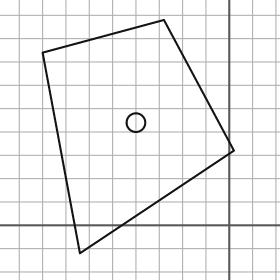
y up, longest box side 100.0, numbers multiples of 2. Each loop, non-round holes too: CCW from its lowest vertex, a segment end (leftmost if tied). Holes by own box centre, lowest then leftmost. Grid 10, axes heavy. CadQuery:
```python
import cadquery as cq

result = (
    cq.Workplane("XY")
    .moveTo(-64.0, -12.0)
    .lineTo(2.0, 32.0)
    .lineTo(-28.0, 88.0)
    .lineTo(-80.0, 74.0)
    .close()
    .moveTo(-40.0, 44.0)
    .circle(4.0)
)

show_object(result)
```